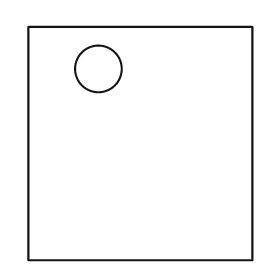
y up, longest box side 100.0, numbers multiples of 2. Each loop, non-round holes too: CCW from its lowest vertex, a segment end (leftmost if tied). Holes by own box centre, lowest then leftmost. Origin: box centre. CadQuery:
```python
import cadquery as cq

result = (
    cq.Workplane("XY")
    .moveTo(-48.0, -50.0)
    .lineTo(48.0, -50.0)
    .lineTo(48.0, 50.0)
    .lineTo(-48.0, 50.0)
    .close()
    .moveTo(-18.0, 32.0)
    .circle(10.0)
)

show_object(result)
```